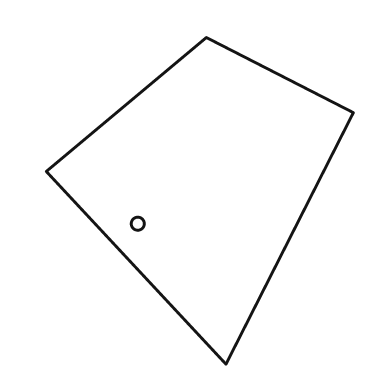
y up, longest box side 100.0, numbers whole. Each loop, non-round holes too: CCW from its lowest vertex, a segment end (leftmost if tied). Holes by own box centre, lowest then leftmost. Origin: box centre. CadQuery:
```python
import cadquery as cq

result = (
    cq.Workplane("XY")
    .moveTo(8.0, -50.0)
    .lineTo(47.0, 27.0)
    .lineTo(2.0, 50.0)
    .lineTo(-47.0, 9.0)
    .close()
    .moveTo(-19.0, -7.0)
    .circle(2.0)
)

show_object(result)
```